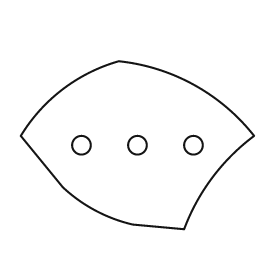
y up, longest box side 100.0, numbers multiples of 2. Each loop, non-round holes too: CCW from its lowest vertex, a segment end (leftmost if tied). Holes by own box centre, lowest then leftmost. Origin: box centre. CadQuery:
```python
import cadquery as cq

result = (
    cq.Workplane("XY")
    .moveTo(20.0, -36.0)
    .threePointArc((32.0, -14.0), (50.0, 4.0))
    .threePointArc((24.0, 26.0), (-8.0, 36.0))
    .threePointArc((-32.0, 24.0), (-50.0, 4.0))
    .lineTo(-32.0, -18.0)
    .threePointArc((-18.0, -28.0), (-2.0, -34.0))
    .close()
    .moveTo(-24.0, 0.0)
    .circle(4.0)
    .moveTo(0.0, 0.0)
    .circle(4.0)
    .moveTo(24.0, 0.0)
    .circle(4.0)
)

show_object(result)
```